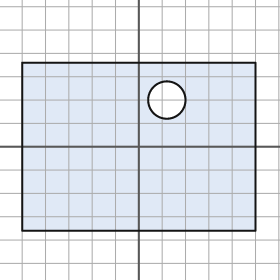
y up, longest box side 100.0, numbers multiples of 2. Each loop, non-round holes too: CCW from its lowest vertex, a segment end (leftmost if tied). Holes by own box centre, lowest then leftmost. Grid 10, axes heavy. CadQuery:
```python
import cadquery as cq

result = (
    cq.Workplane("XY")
    .moveTo(-50.0, -36.0)
    .lineTo(50.0, -36.0)
    .lineTo(50.0, 36.0)
    .lineTo(-50.0, 36.0)
    .close()
    .moveTo(12.0, 20.0)
    .circle(8.0)
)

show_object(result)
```